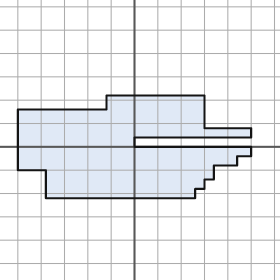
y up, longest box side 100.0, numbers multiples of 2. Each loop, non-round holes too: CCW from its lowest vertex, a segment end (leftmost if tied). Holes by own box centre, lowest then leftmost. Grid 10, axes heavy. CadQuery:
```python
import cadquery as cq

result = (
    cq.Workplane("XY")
    .moveTo(-38.0, -22.0)
    .lineTo(26.0, -22.0)
    .lineTo(26.0, -18.0)
    .lineTo(30.0, -18.0)
    .lineTo(30.0, -14.0)
    .lineTo(34.0, -14.0)
    .lineTo(34.0, -8.0)
    .lineTo(44.0, -8.0)
    .lineTo(44.0, -4.0)
    .lineTo(50.0, -4.0)
    .lineTo(50.0, 0.0)
    .lineTo(0.0, 0.0)
    .lineTo(0.0, 4.0)
    .lineTo(50.0, 4.0)
    .lineTo(50.0, 8.0)
    .lineTo(30.0, 8.0)
    .lineTo(30.0, 22.0)
    .lineTo(-12.0, 22.0)
    .lineTo(-12.0, 16.0)
    .lineTo(-50.0, 16.0)
    .lineTo(-50.0, -10.0)
    .lineTo(-38.0, -10.0)
    .close()
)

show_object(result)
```